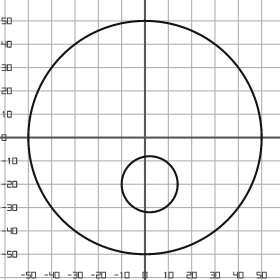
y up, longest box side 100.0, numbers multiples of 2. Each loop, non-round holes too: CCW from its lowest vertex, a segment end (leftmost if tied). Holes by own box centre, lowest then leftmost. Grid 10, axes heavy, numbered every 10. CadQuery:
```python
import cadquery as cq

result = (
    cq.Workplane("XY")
    .moveTo(0.0, 0.0)
    .circle(50.0)
    .moveTo(2.0, -20.0)
    .circle(12.0)
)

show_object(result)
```